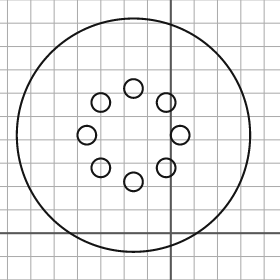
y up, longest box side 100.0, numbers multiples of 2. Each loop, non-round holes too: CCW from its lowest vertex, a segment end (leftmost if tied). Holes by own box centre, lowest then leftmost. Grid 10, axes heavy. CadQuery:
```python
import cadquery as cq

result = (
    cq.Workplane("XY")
    .moveTo(-16.0, 42.0)
    .circle(50.0)
    .moveTo(-16.0, 22.0)
    .circle(4.0)
    .moveTo(-30.0, 28.0)
    .circle(4.0)
    .moveTo(-2.0, 28.0)
    .circle(4.0)
    .moveTo(-36.0, 42.0)
    .circle(4.0)
    .moveTo(4.0, 42.0)
    .circle(4.0)
    .moveTo(-30.0, 56.0)
    .circle(4.0)
    .moveTo(-2.0, 56.0)
    .circle(4.0)
    .moveTo(-16.0, 62.0)
    .circle(4.0)
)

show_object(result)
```